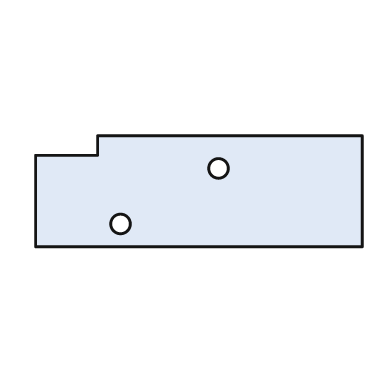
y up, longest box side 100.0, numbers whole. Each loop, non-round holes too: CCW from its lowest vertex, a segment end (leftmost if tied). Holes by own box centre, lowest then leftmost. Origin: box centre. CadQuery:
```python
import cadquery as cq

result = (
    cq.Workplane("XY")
    .moveTo(-50.0, -17.0)
    .lineTo(50.0, -17.0)
    .lineTo(50.0, 17.0)
    .lineTo(-31.0, 17.0)
    .lineTo(-31.0, 11.0)
    .lineTo(-50.0, 11.0)
    .close()
    .moveTo(-24.0, -10.0)
    .circle(3.0)
    .moveTo(6.0, 7.0)
    .circle(3.0)
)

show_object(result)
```